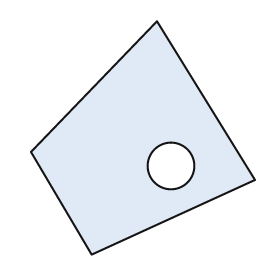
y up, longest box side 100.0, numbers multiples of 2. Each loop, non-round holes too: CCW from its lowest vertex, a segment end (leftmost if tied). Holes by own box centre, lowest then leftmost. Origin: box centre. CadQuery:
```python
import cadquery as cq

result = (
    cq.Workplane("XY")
    .moveTo(-22.0, -50.0)
    .lineTo(48.0, -18.0)
    .lineTo(6.0, 50.0)
    .lineTo(-48.0, -6.0)
    .close()
    .moveTo(12.0, -12.0)
    .circle(10.0)
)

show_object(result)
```